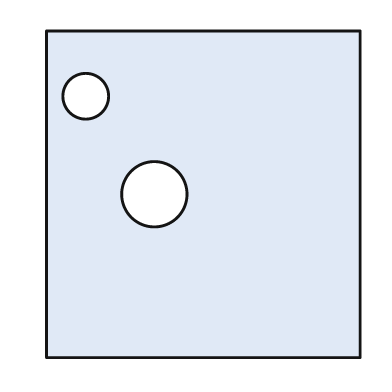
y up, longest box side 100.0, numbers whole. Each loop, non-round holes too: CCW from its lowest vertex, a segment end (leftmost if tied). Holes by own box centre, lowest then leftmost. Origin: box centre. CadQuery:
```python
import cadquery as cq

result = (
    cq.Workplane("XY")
    .moveTo(-48.0, -50.0)
    .lineTo(48.0, -50.0)
    .lineTo(48.0, 50.0)
    .lineTo(-48.0, 50.0)
    .close()
    .moveTo(-15.0, 0.0)
    .circle(10.0)
    .moveTo(-36.0, 30.0)
    .circle(7.0)
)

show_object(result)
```